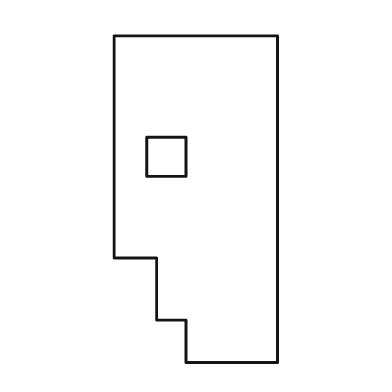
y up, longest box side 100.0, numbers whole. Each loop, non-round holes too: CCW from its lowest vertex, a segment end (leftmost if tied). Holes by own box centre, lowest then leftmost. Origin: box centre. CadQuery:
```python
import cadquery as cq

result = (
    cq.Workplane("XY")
    .moveTo(-3.0, -50.0)
    .lineTo(25.0, -50.0)
    .lineTo(25.0, 50.0)
    .lineTo(-25.0, 50.0)
    .lineTo(-25.0, -18.0)
    .lineTo(-12.0, -18.0)
    .lineTo(-12.0, -37.0)
    .lineTo(-3.0, -37.0)
    .close()
    .moveTo(-15.0, 7.0)
    .lineTo(-3.0, 7.0)
    .lineTo(-3.0, 19.0)
    .lineTo(-15.0, 19.0)
    .close()
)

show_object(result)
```